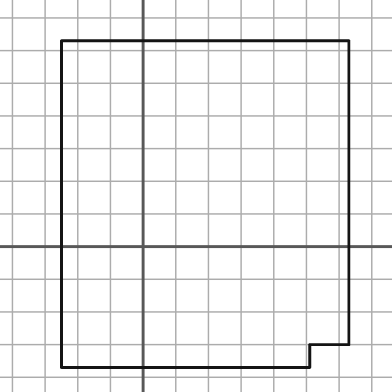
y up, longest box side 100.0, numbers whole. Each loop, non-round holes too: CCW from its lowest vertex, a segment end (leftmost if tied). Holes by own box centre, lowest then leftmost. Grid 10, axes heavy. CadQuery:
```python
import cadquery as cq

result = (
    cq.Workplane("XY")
    .moveTo(-25.0, -37.0)
    .lineTo(51.0, -37.0)
    .lineTo(51.0, -30.0)
    .lineTo(63.0, -30.0)
    .lineTo(63.0, 63.0)
    .lineTo(-25.0, 63.0)
    .close()
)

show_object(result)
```